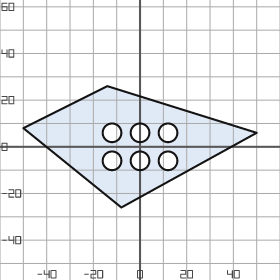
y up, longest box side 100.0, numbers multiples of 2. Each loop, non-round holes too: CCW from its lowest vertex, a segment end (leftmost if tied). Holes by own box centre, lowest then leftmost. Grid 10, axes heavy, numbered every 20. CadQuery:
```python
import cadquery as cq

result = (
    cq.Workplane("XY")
    .moveTo(-8.0, -26.0)
    .lineTo(50.0, 6.0)
    .lineTo(-14.0, 26.0)
    .lineTo(-50.0, 8.0)
    .close()
    .moveTo(-12.0, -6.0)
    .circle(4.0)
    .moveTo(0.0, -6.0)
    .circle(4.0)
    .moveTo(12.0, -6.0)
    .circle(4.0)
    .moveTo(-12.0, 6.0)
    .circle(4.0)
    .moveTo(0.0, 6.0)
    .circle(4.0)
    .moveTo(12.0, 6.0)
    .circle(4.0)
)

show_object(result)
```